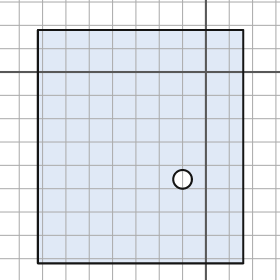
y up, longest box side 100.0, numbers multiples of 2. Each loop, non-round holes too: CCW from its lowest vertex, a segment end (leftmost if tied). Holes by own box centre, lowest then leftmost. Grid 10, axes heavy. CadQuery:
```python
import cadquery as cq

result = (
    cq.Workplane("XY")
    .moveTo(-72.0, -82.0)
    .lineTo(16.0, -82.0)
    .lineTo(16.0, 18.0)
    .lineTo(-72.0, 18.0)
    .close()
    .moveTo(-10.0, -46.0)
    .circle(4.0)
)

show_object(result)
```